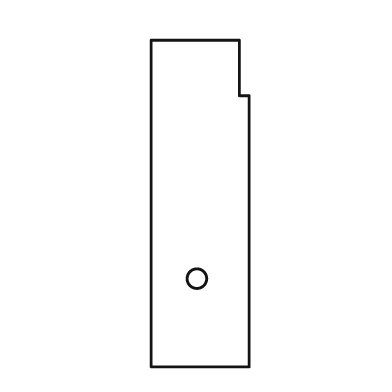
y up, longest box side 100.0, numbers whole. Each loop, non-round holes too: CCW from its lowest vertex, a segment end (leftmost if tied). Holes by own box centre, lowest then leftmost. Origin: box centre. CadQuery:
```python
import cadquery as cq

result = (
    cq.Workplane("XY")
    .moveTo(-15.0, -50.0)
    .lineTo(15.0, -50.0)
    .lineTo(15.0, 33.0)
    .lineTo(12.0, 33.0)
    .lineTo(12.0, 50.0)
    .lineTo(-15.0, 50.0)
    .close()
    .moveTo(-1.0, -23.0)
    .circle(3.0)
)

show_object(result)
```